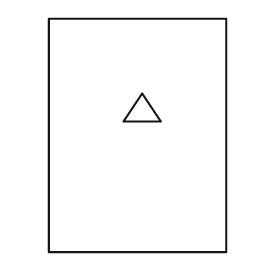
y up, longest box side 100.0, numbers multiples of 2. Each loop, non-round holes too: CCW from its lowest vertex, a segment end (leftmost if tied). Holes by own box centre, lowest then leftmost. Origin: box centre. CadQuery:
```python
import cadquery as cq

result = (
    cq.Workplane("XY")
    .moveTo(-38.0, -50.0)
    .lineTo(38.0, -50.0)
    .lineTo(38.0, 50.0)
    .lineTo(-38.0, 50.0)
    .close()
    .moveTo(-6.0, 6.0)
    .lineTo(10.0, 6.0)
    .lineTo(2.0, 18.0)
    .close()
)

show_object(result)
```